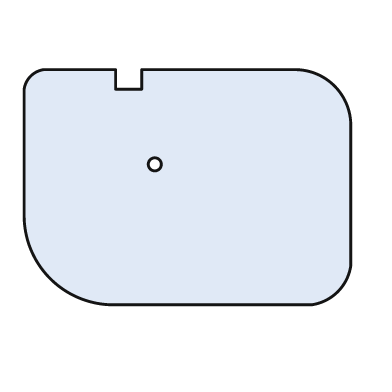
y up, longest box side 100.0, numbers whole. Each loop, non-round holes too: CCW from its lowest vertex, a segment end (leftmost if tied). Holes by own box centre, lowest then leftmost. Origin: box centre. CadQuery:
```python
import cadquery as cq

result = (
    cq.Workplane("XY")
    .moveTo(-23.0, -36.0)
    .lineTo(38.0, -36.0)
    .threePointArc((46.0, -32.0), (50.0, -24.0))
    .lineTo(50.0, 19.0)
    .threePointArc((45.0, 31.0), (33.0, 36.0))
    .lineTo(-14.0, 36.0)
    .lineTo(-14.0, 30.0)
    .lineTo(-22.0, 30.0)
    .lineTo(-22.0, 36.0)
    .lineTo(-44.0, 36.0)
    .threePointArc((-48.0, 34.0), (-50.0, 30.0))
    .lineTo(-50.0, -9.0)
    .threePointArc((-42.0, -28.0), (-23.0, -36.0))
    .close()
    .moveTo(-10.0, 7.0)
    .circle(2.0)
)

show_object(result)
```